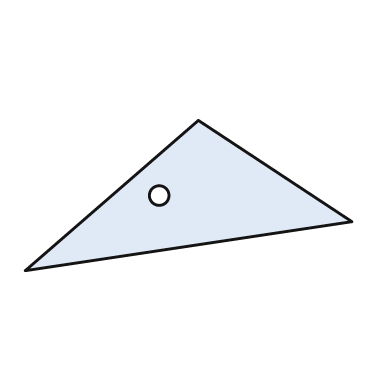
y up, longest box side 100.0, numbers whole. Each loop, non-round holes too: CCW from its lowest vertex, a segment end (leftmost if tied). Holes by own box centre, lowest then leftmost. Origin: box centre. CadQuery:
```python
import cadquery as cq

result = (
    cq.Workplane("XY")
    .moveTo(-50.0, -23.0)
    .lineTo(50.0, -8.0)
    .lineTo(3.0, 23.0)
    .close()
    .moveTo(-9.0, 0.0)
    .circle(3.0)
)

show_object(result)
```